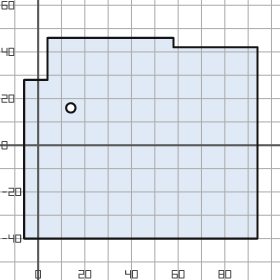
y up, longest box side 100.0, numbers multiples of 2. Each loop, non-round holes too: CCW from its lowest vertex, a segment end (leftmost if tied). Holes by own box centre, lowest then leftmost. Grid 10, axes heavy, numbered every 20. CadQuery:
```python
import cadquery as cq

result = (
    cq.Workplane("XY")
    .moveTo(-6.0, -40.0)
    .lineTo(94.0, -40.0)
    .lineTo(94.0, 42.0)
    .lineTo(58.0, 42.0)
    .lineTo(58.0, 46.0)
    .lineTo(4.0, 46.0)
    .lineTo(4.0, 28.0)
    .lineTo(-6.0, 28.0)
    .close()
    .moveTo(14.0, 16.0)
    .circle(2.0)
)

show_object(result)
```